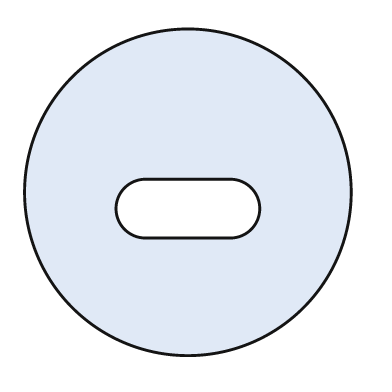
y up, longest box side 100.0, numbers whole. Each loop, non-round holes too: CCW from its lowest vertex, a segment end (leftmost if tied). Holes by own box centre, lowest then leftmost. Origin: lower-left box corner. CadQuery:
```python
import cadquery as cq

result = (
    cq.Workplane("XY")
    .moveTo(50.0, 50.0)
    .circle(50.0)
    .moveTo(37.0, 36.0)
    .lineTo(63.0, 36.0)
    .threePointArc((72.0, 45.0), (63.0, 54.0))
    .lineTo(37.0, 54.0)
    .threePointArc((28.0, 45.0), (37.0, 36.0))
    .close()
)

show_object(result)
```